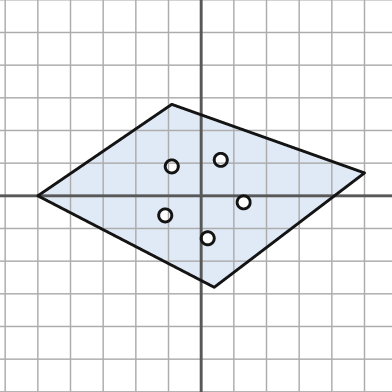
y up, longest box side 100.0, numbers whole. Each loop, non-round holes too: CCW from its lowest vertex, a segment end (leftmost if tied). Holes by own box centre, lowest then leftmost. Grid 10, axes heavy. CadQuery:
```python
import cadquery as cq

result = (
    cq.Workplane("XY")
    .moveTo(4.0, -28.0)
    .lineTo(50.0, 7.0)
    .lineTo(-9.0, 28.0)
    .lineTo(-50.0, 0.0)
    .close()
    .moveTo(2.0, -13.0)
    .circle(2.0)
    .moveTo(-11.0, -6.0)
    .circle(2.0)
    .moveTo(13.0, -2.0)
    .circle(2.0)
    .moveTo(-9.0, 9.0)
    .circle(2.0)
    .moveTo(6.0, 11.0)
    .circle(2.0)
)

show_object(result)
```